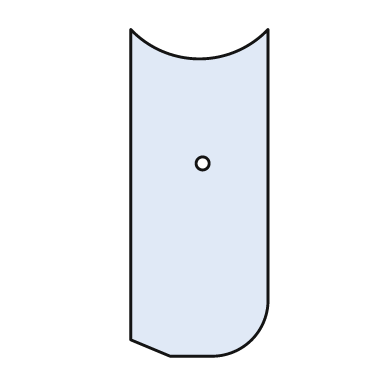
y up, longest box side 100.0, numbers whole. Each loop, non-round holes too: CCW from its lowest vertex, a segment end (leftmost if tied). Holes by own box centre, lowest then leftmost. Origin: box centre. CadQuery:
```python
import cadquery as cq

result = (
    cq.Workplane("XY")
    .moveTo(-9.0, -50.0)
    .lineTo(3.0, -50.0)
    .threePointArc((16.0, -45.0), (21.0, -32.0))
    .lineTo(21.0, 50.0)
    .threePointArc((0.0, 41.0), (-21.0, 50.0))
    .lineTo(-21.0, -45.0)
    .close()
    .moveTo(1.0, 9.0)
    .circle(2.0)
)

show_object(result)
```